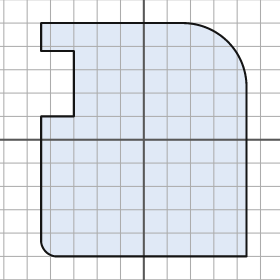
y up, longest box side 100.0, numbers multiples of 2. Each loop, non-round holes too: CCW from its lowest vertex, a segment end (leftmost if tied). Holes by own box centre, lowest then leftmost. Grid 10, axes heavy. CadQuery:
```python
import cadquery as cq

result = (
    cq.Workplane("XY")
    .moveTo(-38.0, -50.0)
    .lineTo(44.0, -50.0)
    .lineTo(44.0, 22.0)
    .threePointArc((36.0, 42.0), (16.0, 50.0))
    .lineTo(-44.0, 50.0)
    .lineTo(-44.0, 38.0)
    .lineTo(-30.0, 38.0)
    .lineTo(-30.0, 10.0)
    .lineTo(-44.0, 10.0)
    .lineTo(-44.0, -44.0)
    .threePointArc((-42.0, -48.0), (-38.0, -50.0))
    .close()
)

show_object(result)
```